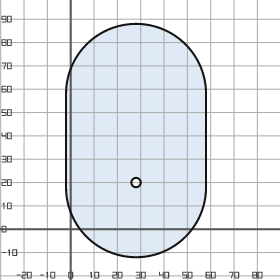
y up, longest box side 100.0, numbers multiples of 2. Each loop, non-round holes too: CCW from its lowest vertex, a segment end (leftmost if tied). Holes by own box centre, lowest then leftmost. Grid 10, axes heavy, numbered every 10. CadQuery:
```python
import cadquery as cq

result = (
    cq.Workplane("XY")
    .moveTo(-2.0, 18.0)
    .threePointArc((28.0, -12.0), (58.0, 18.0))
    .lineTo(58.0, 58.0)
    .threePointArc((28.0, 88.0), (-2.0, 58.0))
    .close()
    .moveTo(28.0, 20.0)
    .circle(2.0)
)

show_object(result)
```